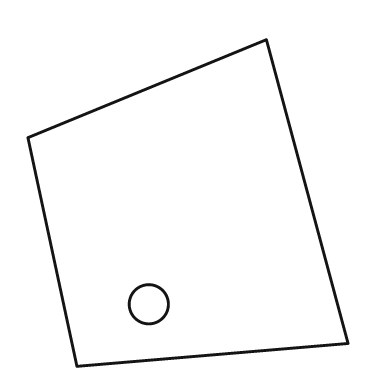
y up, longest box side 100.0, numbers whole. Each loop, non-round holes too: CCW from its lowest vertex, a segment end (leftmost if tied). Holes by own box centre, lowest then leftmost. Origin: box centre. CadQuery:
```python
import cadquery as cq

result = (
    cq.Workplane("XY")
    .moveTo(-34.0, -50.0)
    .lineTo(49.0, -43.0)
    .lineTo(24.0, 50.0)
    .lineTo(-49.0, 20.0)
    .close()
    .moveTo(-12.0, -31.0)
    .circle(6.0)
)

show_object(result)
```